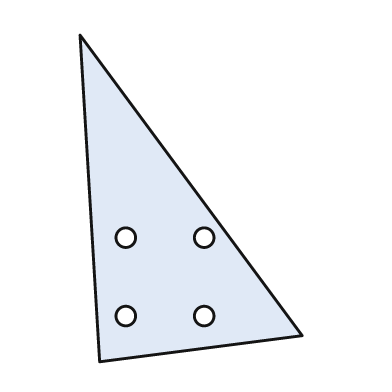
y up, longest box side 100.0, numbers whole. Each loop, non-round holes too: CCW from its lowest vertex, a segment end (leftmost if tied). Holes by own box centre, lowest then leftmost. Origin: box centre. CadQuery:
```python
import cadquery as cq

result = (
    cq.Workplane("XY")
    .moveTo(-28.0, -50.0)
    .lineTo(34.0, -42.0)
    .lineTo(-34.0, 50.0)
    .close()
    .moveTo(-20.0, -36.0)
    .circle(3.0)
    .moveTo(4.0, -36.0)
    .circle(3.0)
    .moveTo(-20.0, -12.0)
    .circle(3.0)
    .moveTo(4.0, -12.0)
    .circle(3.0)
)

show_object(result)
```